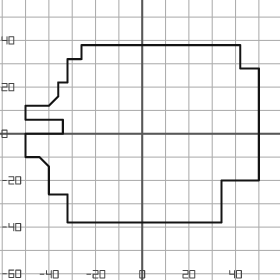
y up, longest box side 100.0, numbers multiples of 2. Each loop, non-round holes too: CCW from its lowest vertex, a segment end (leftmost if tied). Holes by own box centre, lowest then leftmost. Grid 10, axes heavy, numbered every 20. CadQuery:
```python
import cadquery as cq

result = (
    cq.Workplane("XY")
    .moveTo(-32.0, -38.0)
    .lineTo(34.0, -38.0)
    .lineTo(34.0, -20.0)
    .lineTo(50.0, -20.0)
    .lineTo(50.0, 28.0)
    .lineTo(42.0, 28.0)
    .lineTo(42.0, 38.0)
    .lineTo(-26.0, 38.0)
    .lineTo(-26.0, 32.0)
    .lineTo(-32.0, 32.0)
    .lineTo(-32.0, 22.0)
    .lineTo(-36.0, 22.0)
    .lineTo(-36.0, 16.0)
    .lineTo(-40.0, 12.0)
    .lineTo(-50.0, 12.0)
    .lineTo(-50.0, 6.0)
    .lineTo(-34.0, 6.0)
    .lineTo(-34.0, 0.0)
    .lineTo(-50.0, 0.0)
    .lineTo(-50.0, -10.0)
    .lineTo(-44.0, -10.0)
    .lineTo(-40.0, -14.0)
    .lineTo(-40.0, -26.0)
    .lineTo(-32.0, -26.0)
    .close()
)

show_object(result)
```